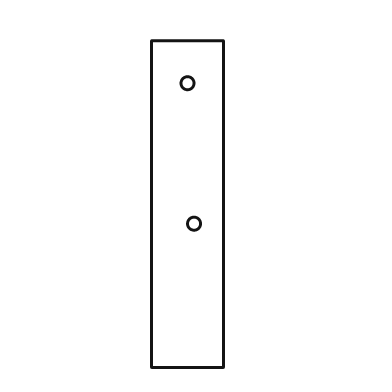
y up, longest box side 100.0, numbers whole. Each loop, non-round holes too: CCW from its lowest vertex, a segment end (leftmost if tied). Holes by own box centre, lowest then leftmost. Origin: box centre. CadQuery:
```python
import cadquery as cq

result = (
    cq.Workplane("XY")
    .moveTo(-11.0, -50.0)
    .lineTo(11.0, -50.0)
    .lineTo(11.0, 50.0)
    .lineTo(-11.0, 50.0)
    .close()
    .moveTo(2.0, -6.0)
    .circle(2.0)
    .moveTo(0.0, 37.0)
    .circle(2.0)
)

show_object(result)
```